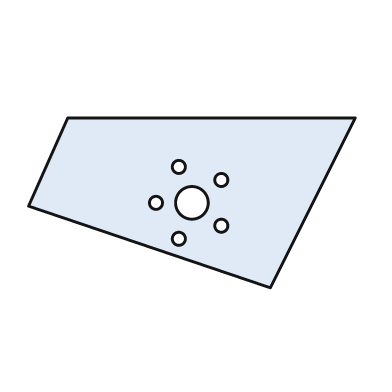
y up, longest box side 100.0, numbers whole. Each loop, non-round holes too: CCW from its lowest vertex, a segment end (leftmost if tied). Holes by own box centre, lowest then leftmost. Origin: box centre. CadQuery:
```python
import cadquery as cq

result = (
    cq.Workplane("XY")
    .moveTo(24.0, -26.0)
    .lineTo(50.0, 26.0)
    .lineTo(-38.0, 26.0)
    .lineTo(-50.0, -1.0)
    .close()
    .moveTo(-4.0, -11.0)
    .circle(2.0)
    .moveTo(9.0, -7.0)
    .circle(2.0)
    .moveTo(-11.0, 0.0)
    .circle(2.0)
    .moveTo(0.0, 0.0)
    .circle(5.0)
    .moveTo(9.0, 7.0)
    .circle(2.0)
    .moveTo(-4.0, 11.0)
    .circle(2.0)
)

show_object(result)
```